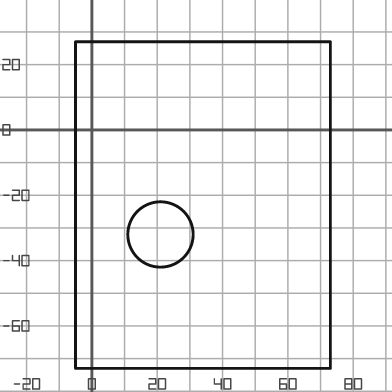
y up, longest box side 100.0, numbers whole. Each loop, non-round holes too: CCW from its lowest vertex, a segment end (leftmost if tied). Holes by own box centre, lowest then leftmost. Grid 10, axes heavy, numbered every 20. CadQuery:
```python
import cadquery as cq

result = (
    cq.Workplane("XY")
    .moveTo(-5.0, -73.0)
    .lineTo(73.0, -73.0)
    .lineTo(73.0, 27.0)
    .lineTo(-5.0, 27.0)
    .close()
    .moveTo(21.0, -32.0)
    .circle(10.0)
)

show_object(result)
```